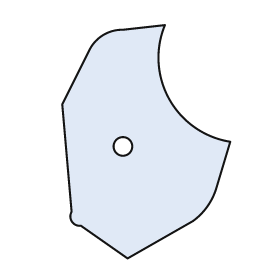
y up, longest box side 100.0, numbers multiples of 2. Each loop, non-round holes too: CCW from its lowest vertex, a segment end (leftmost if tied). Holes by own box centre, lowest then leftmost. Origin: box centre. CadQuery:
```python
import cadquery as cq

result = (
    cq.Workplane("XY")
    .moveTo(-8.0, -50.0)
    .lineTo(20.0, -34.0)
    .threePointArc((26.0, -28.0), (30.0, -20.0))
    .lineTo(36.0, 0.0)
    .threePointArc((10.0, 18.0), (8.0, 50.0))
    .lineTo(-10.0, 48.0)
    .threePointArc((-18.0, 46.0), (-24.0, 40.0))
    .lineTo(-36.0, 16.0)
    .lineTo(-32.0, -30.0)
    .threePointArc((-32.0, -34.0), (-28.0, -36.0))
    .close()
    .moveTo(-10.0, -2.0)
    .circle(4.0)
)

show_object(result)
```